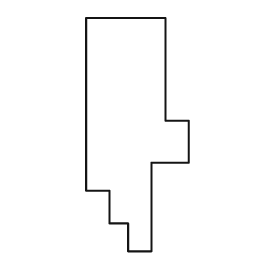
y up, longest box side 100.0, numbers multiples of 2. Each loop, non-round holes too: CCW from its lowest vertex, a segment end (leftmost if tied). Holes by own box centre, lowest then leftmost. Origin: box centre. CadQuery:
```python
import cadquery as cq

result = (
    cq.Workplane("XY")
    .moveTo(-4.0, -50.0)
    .lineTo(6.0, -50.0)
    .lineTo(6.0, -12.0)
    .lineTo(22.0, -12.0)
    .lineTo(22.0, 6.0)
    .lineTo(12.0, 6.0)
    .lineTo(12.0, 50.0)
    .lineTo(-22.0, 50.0)
    .lineTo(-22.0, -24.0)
    .lineTo(-12.0, -24.0)
    .lineTo(-12.0, -38.0)
    .lineTo(-4.0, -38.0)
    .close()
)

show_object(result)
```